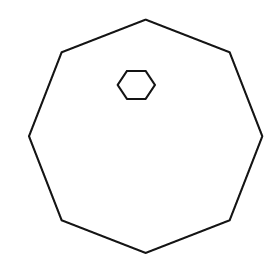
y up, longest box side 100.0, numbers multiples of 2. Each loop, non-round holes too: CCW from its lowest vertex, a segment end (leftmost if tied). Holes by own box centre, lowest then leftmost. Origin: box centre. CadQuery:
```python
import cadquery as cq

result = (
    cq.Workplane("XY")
    .moveTo(0.0, -50.0)
    .lineTo(36.0, -36.0)
    .lineTo(50.0, 0.0)
    .lineTo(36.0, 36.0)
    .lineTo(0.0, 50.0)
    .lineTo(-36.0, 36.0)
    .lineTo(-50.0, 0.0)
    .lineTo(-36.0, -36.0)
    .close()
    .moveTo(-8.0, 16.0)
    .lineTo(0.0, 16.0)
    .lineTo(4.0, 22.0)
    .lineTo(0.0, 28.0)
    .lineTo(-8.0, 28.0)
    .lineTo(-12.0, 22.0)
    .close()
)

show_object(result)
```